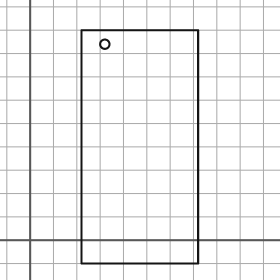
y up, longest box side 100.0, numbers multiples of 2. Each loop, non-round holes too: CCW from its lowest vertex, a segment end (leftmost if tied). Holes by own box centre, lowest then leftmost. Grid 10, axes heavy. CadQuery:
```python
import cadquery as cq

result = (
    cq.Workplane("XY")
    .moveTo(22.0, -10.0)
    .lineTo(72.0, -10.0)
    .lineTo(72.0, 90.0)
    .lineTo(22.0, 90.0)
    .close()
    .moveTo(32.0, 84.0)
    .circle(2.0)
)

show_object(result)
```